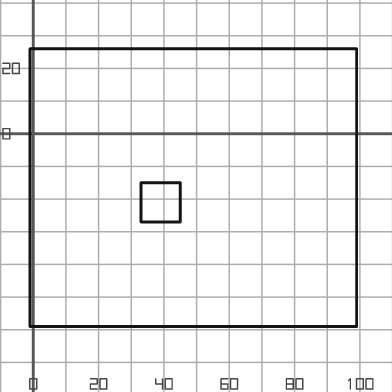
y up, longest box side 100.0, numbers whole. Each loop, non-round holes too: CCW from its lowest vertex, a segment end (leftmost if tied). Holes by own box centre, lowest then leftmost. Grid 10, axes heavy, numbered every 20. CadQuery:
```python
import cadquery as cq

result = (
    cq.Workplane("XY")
    .moveTo(-1.0, -59.0)
    .lineTo(99.0, -59.0)
    .lineTo(99.0, 26.0)
    .lineTo(-1.0, 26.0)
    .close()
    .moveTo(33.0, -27.0)
    .lineTo(45.0, -27.0)
    .lineTo(45.0, -15.0)
    .lineTo(33.0, -15.0)
    .close()
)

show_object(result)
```